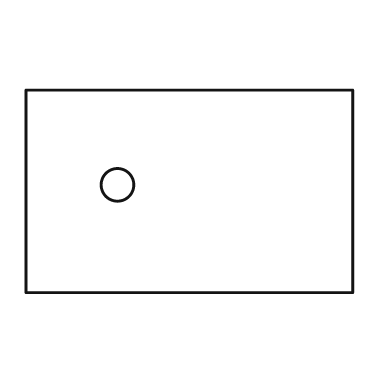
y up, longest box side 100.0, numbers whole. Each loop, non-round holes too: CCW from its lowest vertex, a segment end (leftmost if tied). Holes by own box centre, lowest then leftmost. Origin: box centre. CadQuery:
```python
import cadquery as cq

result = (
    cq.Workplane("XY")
    .moveTo(-50.0, -31.0)
    .lineTo(50.0, -31.0)
    .lineTo(50.0, 31.0)
    .lineTo(-50.0, 31.0)
    .close()
    .moveTo(-22.0, 2.0)
    .circle(5.0)
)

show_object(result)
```